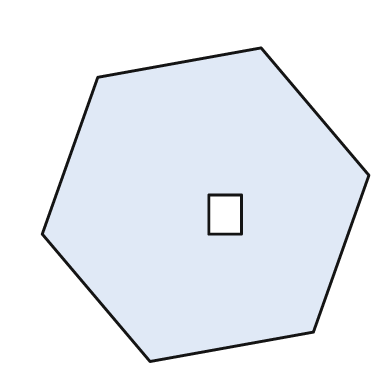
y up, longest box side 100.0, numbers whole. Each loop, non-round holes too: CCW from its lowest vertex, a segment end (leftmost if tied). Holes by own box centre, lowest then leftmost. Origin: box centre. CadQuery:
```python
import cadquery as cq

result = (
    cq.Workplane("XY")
    .moveTo(-17.0, -48.0)
    .lineTo(33.0, -39.0)
    .lineTo(50.0, 9.0)
    .lineTo(17.0, 48.0)
    .lineTo(-33.0, 39.0)
    .lineTo(-50.0, -9.0)
    .close()
    .moveTo(1.0, -9.0)
    .lineTo(11.0, -9.0)
    .lineTo(11.0, 3.0)
    .lineTo(1.0, 3.0)
    .close()
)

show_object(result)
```